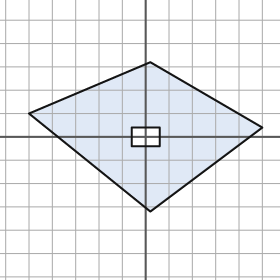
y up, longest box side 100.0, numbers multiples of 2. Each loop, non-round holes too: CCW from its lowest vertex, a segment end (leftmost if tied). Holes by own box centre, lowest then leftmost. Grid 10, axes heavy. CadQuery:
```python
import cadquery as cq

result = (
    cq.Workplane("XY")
    .moveTo(2.0, -32.0)
    .lineTo(50.0, 4.0)
    .lineTo(2.0, 32.0)
    .lineTo(-50.0, 10.0)
    .close()
    .moveTo(-6.0, -4.0)
    .lineTo(6.0, -4.0)
    .lineTo(6.0, 4.0)
    .lineTo(-6.0, 4.0)
    .close()
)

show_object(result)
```